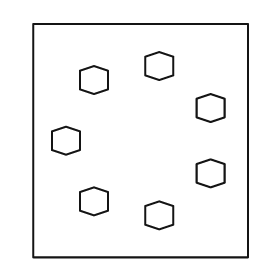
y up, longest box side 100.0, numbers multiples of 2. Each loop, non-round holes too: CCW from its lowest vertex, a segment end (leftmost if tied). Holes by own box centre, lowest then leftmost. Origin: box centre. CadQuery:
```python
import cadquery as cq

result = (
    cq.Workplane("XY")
    .moveTo(-46.0, -50.0)
    .lineTo(46.0, -50.0)
    .lineTo(46.0, 50.0)
    .lineTo(-46.0, 50.0)
    .close()
    .moveTo(8.0, -38.0)
    .lineTo(14.0, -36.0)
    .lineTo(14.0, -28.0)
    .lineTo(8.0, -26.0)
    .lineTo(2.0, -28.0)
    .lineTo(2.0, -36.0)
    .close()
    .moveTo(-20.0, -32.0)
    .lineTo(-14.0, -30.0)
    .lineTo(-14.0, -22.0)
    .lineTo(-20.0, -20.0)
    .lineTo(-26.0, -22.0)
    .lineTo(-26.0, -30.0)
    .close()
    .moveTo(30.0, -20.0)
    .lineTo(36.0, -18.0)
    .lineTo(36.0, -10.0)
    .lineTo(30.0, -8.0)
    .lineTo(24.0, -10.0)
    .lineTo(24.0, -18.0)
    .close()
    .moveTo(-32.0, -6.0)
    .lineTo(-26.0, -4.0)
    .lineTo(-26.0, 4.0)
    .lineTo(-32.0, 6.0)
    .lineTo(-38.0, 4.0)
    .lineTo(-38.0, -4.0)
    .close()
    .moveTo(30.0, 8.0)
    .lineTo(36.0, 10.0)
    .lineTo(36.0, 18.0)
    .lineTo(30.0, 20.0)
    .lineTo(24.0, 18.0)
    .lineTo(24.0, 10.0)
    .close()
    .moveTo(-20.0, 20.0)
    .lineTo(-14.0, 22.0)
    .lineTo(-14.0, 30.0)
    .lineTo(-20.0, 32.0)
    .lineTo(-26.0, 30.0)
    .lineTo(-26.0, 22.0)
    .close()
    .moveTo(8.0, 26.0)
    .lineTo(14.0, 28.0)
    .lineTo(14.0, 36.0)
    .lineTo(8.0, 38.0)
    .lineTo(2.0, 36.0)
    .lineTo(2.0, 28.0)
    .close()
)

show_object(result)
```